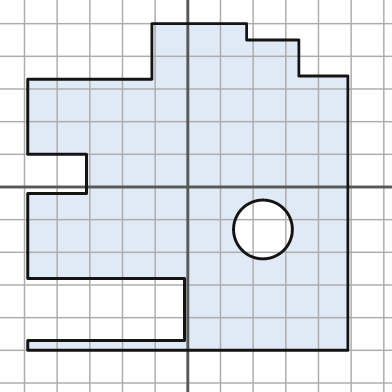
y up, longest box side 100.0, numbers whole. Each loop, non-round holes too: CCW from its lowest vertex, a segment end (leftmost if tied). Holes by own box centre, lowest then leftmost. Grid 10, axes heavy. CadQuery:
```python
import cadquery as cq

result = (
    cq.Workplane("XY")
    .moveTo(-49.0, -50.0)
    .lineTo(49.0, -50.0)
    .lineTo(49.0, 34.0)
    .lineTo(34.0, 34.0)
    .lineTo(34.0, 45.0)
    .lineTo(18.0, 45.0)
    .lineTo(18.0, 50.0)
    .lineTo(-11.0, 50.0)
    .lineTo(-11.0, 33.0)
    .lineTo(-49.0, 33.0)
    .lineTo(-49.0, 10.0)
    .lineTo(-31.0, 10.0)
    .lineTo(-31.0, -2.0)
    .lineTo(-49.0, -2.0)
    .lineTo(-49.0, -28.0)
    .lineTo(-1.0, -28.0)
    .lineTo(-1.0, -47.0)
    .lineTo(-49.0, -47.0)
    .close()
    .moveTo(23.0, -13.0)
    .circle(9.0)
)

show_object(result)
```